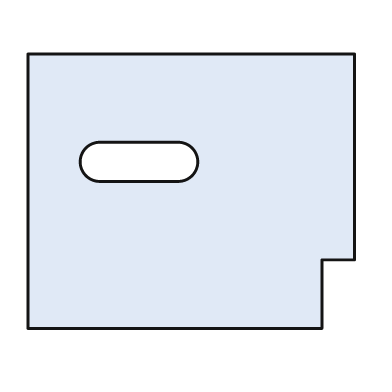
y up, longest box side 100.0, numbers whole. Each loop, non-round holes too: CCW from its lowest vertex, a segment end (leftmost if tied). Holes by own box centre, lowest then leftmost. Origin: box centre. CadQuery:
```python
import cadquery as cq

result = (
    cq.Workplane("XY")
    .moveTo(-50.0, -42.0)
    .lineTo(40.0, -42.0)
    .lineTo(40.0, -21.0)
    .lineTo(50.0, -21.0)
    .lineTo(50.0, 42.0)
    .lineTo(-50.0, 42.0)
    .close()
    .moveTo(-28.0, 3.0)
    .lineTo(-4.0, 3.0)
    .threePointArc((2.0, 9.0), (-4.0, 15.0))
    .lineTo(-28.0, 15.0)
    .threePointArc((-34.0, 9.0), (-28.0, 3.0))
    .close()
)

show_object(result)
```